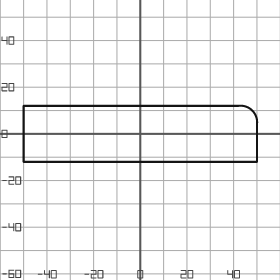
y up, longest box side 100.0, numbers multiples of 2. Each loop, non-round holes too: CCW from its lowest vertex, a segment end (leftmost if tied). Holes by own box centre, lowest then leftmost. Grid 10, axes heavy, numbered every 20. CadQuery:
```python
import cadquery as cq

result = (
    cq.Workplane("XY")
    .moveTo(-50.0, -12.0)
    .lineTo(50.0, -12.0)
    .lineTo(50.0, 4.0)
    .threePointArc((48.0, 10.0), (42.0, 12.0))
    .lineTo(-50.0, 12.0)
    .close()
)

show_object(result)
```